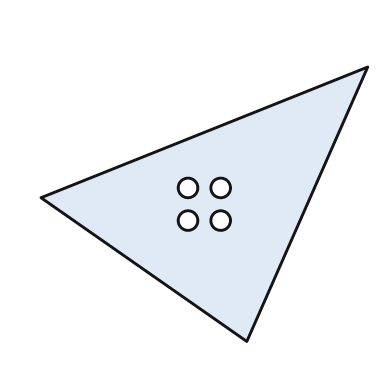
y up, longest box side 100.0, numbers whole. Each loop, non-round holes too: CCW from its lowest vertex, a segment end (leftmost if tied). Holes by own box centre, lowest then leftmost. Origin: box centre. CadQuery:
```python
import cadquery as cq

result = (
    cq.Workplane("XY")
    .moveTo(13.0, -42.0)
    .lineTo(50.0, 42.0)
    .lineTo(-50.0, 2.0)
    .close()
    .moveTo(-5.0, -5.0)
    .circle(3.0)
    .moveTo(5.0, -5.0)
    .circle(3.0)
    .moveTo(-5.0, 5.0)
    .circle(3.0)
    .moveTo(5.0, 5.0)
    .circle(3.0)
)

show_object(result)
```